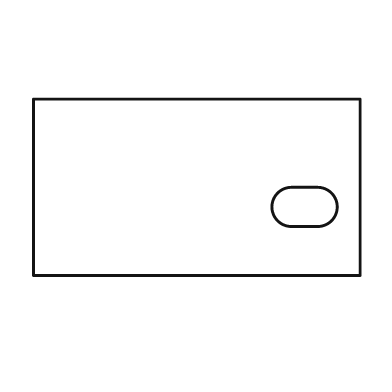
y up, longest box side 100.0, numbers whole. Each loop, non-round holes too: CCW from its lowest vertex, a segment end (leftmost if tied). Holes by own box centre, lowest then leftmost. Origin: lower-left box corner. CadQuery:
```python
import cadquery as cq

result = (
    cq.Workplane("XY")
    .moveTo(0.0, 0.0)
    .lineTo(100.0, 0.0)
    .lineTo(100.0, 54.0)
    .lineTo(0.0, 54.0)
    .close()
    .moveTo(79.0, 15.0)
    .lineTo(87.0, 15.0)
    .threePointArc((93.0, 21.0), (87.0, 27.0))
    .lineTo(79.0, 27.0)
    .threePointArc((73.0, 21.0), (79.0, 15.0))
    .close()
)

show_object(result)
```